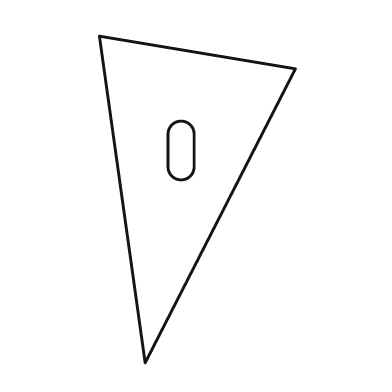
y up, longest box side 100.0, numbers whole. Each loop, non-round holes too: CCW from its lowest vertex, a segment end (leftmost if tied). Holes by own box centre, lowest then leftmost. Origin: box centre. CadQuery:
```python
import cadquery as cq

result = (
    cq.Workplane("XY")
    .moveTo(-16.0, -50.0)
    .lineTo(30.0, 40.0)
    .lineTo(-30.0, 50.0)
    .close()
    .moveTo(-9.0, 10.0)
    .threePointArc((-5.0, 6.0), (-1.0, 10.0))
    .lineTo(-1.0, 20.0)
    .threePointArc((-5.0, 24.0), (-9.0, 20.0))
    .close()
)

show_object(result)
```